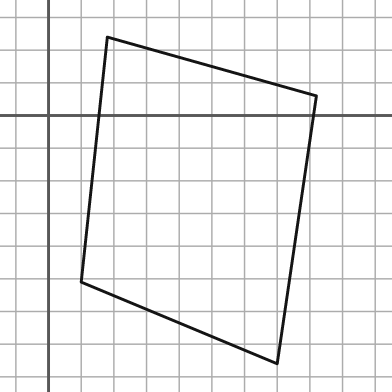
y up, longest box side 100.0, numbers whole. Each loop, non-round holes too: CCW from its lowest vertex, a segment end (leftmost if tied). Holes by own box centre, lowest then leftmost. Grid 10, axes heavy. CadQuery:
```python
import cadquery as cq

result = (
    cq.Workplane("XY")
    .moveTo(70.0, -76.0)
    .lineTo(82.0, 6.0)
    .lineTo(18.0, 24.0)
    .lineTo(10.0, -51.0)
    .close()
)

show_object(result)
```